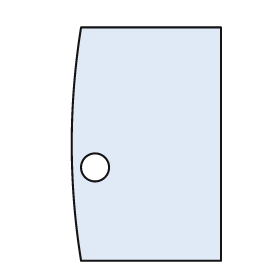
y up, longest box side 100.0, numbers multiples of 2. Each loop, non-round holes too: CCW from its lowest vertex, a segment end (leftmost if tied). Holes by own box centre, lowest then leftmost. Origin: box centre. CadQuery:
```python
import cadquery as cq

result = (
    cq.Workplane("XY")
    .moveTo(-28.0, -50.0)
    .lineTo(32.0, -50.0)
    .lineTo(32.0, 50.0)
    .lineTo(-28.0, 50.0)
    .threePointArc((-32.0, 0.0), (-28.0, -50.0))
    .close()
    .moveTo(-22.0, -10.0)
    .circle(6.0)
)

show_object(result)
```